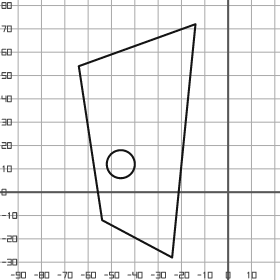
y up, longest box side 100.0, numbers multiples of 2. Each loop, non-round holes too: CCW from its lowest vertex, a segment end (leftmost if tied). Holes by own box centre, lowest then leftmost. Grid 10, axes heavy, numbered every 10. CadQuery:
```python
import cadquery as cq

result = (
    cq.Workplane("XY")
    .moveTo(-24.0, -28.0)
    .lineTo(-14.0, 72.0)
    .lineTo(-64.0, 54.0)
    .lineTo(-54.0, -12.0)
    .close()
    .moveTo(-46.0, 12.0)
    .circle(6.0)
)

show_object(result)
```